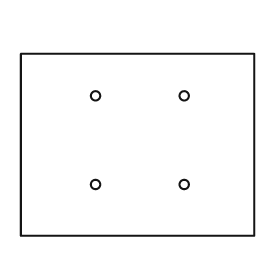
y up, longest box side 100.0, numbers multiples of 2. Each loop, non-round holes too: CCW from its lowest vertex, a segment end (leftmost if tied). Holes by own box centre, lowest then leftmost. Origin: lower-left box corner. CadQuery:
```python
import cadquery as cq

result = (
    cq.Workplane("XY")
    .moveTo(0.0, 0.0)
    .lineTo(100.0, 0.0)
    .lineTo(100.0, 78.0)
    .lineTo(0.0, 78.0)
    .close()
    .moveTo(32.0, 22.0)
    .circle(2.0)
    .moveTo(70.0, 22.0)
    .circle(2.0)
    .moveTo(32.0, 60.0)
    .circle(2.0)
    .moveTo(70.0, 60.0)
    .circle(2.0)
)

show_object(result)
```